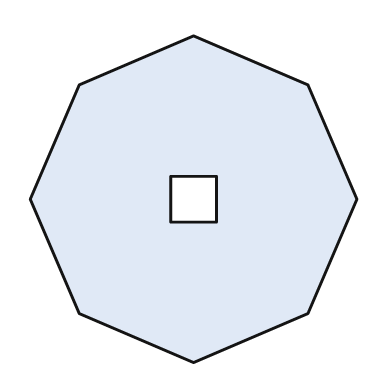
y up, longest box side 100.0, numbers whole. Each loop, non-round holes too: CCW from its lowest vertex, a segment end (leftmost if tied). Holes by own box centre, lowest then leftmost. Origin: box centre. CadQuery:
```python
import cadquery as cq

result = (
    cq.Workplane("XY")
    .moveTo(0.0, -50.0)
    .lineTo(35.0, -35.0)
    .lineTo(50.0, 0.0)
    .lineTo(35.0, 35.0)
    .lineTo(0.0, 50.0)
    .lineTo(-35.0, 35.0)
    .lineTo(-50.0, 0.0)
    .lineTo(-35.0, -35.0)
    .close()
    .moveTo(-7.0, -7.0)
    .lineTo(7.0, -7.0)
    .lineTo(7.0, 7.0)
    .lineTo(-7.0, 7.0)
    .close()
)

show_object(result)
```